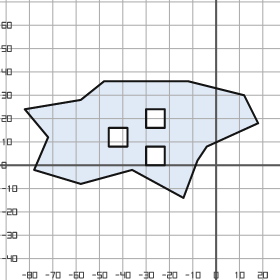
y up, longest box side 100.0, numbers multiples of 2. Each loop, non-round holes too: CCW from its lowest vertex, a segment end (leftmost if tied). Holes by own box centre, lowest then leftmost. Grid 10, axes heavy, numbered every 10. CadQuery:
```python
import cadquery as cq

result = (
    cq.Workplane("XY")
    .moveTo(-14.0, -14.0)
    .lineTo(-8.0, 2.0)
    .lineTo(-4.0, 8.0)
    .lineTo(18.0, 18.0)
    .lineTo(12.0, 30.0)
    .lineTo(-12.0, 36.0)
    .lineTo(-48.0, 36.0)
    .lineTo(-58.0, 28.0)
    .lineTo(-82.0, 24.0)
    .lineTo(-72.0, 12.0)
    .lineTo(-78.0, -2.0)
    .lineTo(-58.0, -8.0)
    .lineTo(-36.0, -2.0)
    .close()
    .moveTo(-30.0, 0.0)
    .lineTo(-22.0, 0.0)
    .lineTo(-22.0, 8.0)
    .lineTo(-30.0, 8.0)
    .close()
    .moveTo(-46.0, 8.0)
    .lineTo(-38.0, 8.0)
    .lineTo(-38.0, 16.0)
    .lineTo(-46.0, 16.0)
    .close()
    .moveTo(-30.0, 16.0)
    .lineTo(-22.0, 16.0)
    .lineTo(-22.0, 24.0)
    .lineTo(-30.0, 24.0)
    .close()
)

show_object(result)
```